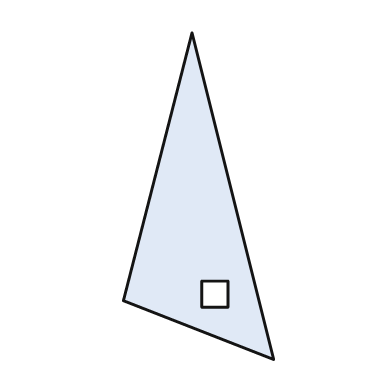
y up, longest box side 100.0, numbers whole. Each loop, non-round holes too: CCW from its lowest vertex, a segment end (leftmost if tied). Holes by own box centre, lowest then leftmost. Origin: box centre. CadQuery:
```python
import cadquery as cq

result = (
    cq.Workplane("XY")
    .moveTo(23.0, -50.0)
    .lineTo(-2.0, 50.0)
    .lineTo(-23.0, -32.0)
    .close()
    .moveTo(1.0, -34.0)
    .lineTo(9.0, -34.0)
    .lineTo(9.0, -26.0)
    .lineTo(1.0, -26.0)
    .close()
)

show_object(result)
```